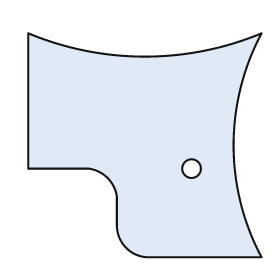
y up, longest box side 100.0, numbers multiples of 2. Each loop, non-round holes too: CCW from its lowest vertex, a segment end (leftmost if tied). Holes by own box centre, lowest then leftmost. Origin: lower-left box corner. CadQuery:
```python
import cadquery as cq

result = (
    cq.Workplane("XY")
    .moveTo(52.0, 0.0)
    .lineTo(100.0, 0.0)
    .threePointArc((88.0, 48.0), (100.0, 96.0))
    .threePointArc((50.0, 86.0), (0.0, 96.0))
    .lineTo(0.0, 38.0)
    .lineTo(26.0, 38.0)
    .threePointArc((34.0, 34.0), (38.0, 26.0))
    .lineTo(38.0, 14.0)
    .threePointArc((42.0, 4.0), (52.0, 0.0))
    .close()
    .moveTo(70.0, 38.0)
    .circle(4.0)
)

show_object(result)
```